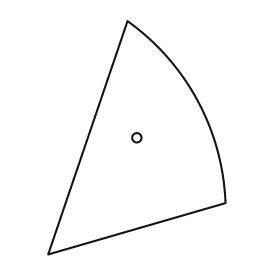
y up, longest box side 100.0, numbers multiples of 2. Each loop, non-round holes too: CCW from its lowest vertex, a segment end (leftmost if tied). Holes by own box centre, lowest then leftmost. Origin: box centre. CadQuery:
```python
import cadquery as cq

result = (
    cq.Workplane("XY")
    .moveTo(-38.0, -50.0)
    .lineTo(38.0, -28.0)
    .threePointArc((26.0, 16.0), (-4.0, 50.0))
    .close()
    .moveTo(0.0, 0.0)
    .circle(2.0)
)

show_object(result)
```